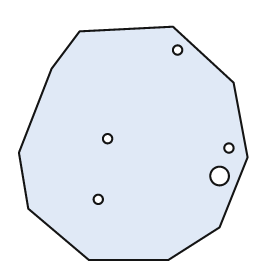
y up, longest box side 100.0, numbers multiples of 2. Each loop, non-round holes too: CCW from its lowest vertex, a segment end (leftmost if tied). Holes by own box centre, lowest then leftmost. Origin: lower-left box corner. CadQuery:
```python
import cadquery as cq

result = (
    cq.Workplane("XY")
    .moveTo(30.0, 0.0)
    .lineTo(64.0, 0.0)
    .lineTo(86.0, 14.0)
    .lineTo(98.0, 44.0)
    .lineTo(92.0, 76.0)
    .lineTo(66.0, 100.0)
    .lineTo(26.0, 98.0)
    .lineTo(14.0, 82.0)
    .lineTo(0.0, 46.0)
    .lineTo(4.0, 22.0)
    .close()
    .moveTo(34.0, 26.0)
    .circle(2.0)
    .moveTo(86.0, 36.0)
    .circle(4.0)
    .moveTo(90.0, 48.0)
    .circle(2.0)
    .moveTo(38.0, 52.0)
    .circle(2.0)
    .moveTo(68.0, 90.0)
    .circle(2.0)
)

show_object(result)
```